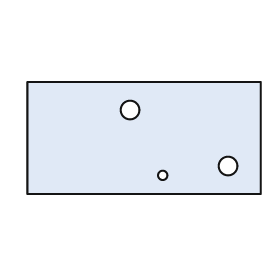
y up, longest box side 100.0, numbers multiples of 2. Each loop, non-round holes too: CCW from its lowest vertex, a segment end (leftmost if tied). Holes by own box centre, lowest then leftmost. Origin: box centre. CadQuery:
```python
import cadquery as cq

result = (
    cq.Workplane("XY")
    .moveTo(-50.0, -24.0)
    .lineTo(50.0, -24.0)
    .lineTo(50.0, 24.0)
    .lineTo(-50.0, 24.0)
    .close()
    .moveTo(8.0, -16.0)
    .circle(2.0)
    .moveTo(36.0, -12.0)
    .circle(4.0)
    .moveTo(-6.0, 12.0)
    .circle(4.0)
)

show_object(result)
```